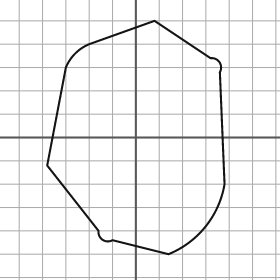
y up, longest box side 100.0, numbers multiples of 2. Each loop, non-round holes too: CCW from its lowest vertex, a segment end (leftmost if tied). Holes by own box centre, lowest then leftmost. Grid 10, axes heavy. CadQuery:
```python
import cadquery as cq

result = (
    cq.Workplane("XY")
    .moveTo(14.0, -50.0)
    .threePointArc((30.0, -38.0), (38.0, -20.0))
    .lineTo(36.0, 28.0)
    .threePointArc((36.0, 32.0), (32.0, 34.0))
    .lineTo(8.0, 50.0)
    .lineTo(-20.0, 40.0)
    .threePointArc((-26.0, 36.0), (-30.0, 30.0))
    .lineTo(-38.0, -12.0)
    .lineTo(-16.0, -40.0)
    .threePointArc((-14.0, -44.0), (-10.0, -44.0))
    .close()
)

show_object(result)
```